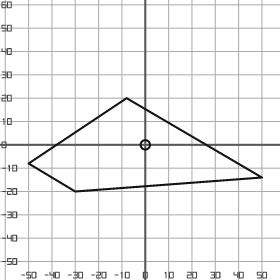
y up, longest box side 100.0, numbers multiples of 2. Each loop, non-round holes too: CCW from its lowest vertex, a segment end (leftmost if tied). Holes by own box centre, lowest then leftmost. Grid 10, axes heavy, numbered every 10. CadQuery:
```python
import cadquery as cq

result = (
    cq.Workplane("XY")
    .moveTo(-30.0, -20.0)
    .lineTo(50.0, -14.0)
    .lineTo(-8.0, 20.0)
    .lineTo(-50.0, -8.0)
    .close()
    .moveTo(0.0, 0.0)
    .circle(2.0)
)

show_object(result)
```